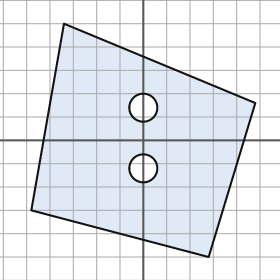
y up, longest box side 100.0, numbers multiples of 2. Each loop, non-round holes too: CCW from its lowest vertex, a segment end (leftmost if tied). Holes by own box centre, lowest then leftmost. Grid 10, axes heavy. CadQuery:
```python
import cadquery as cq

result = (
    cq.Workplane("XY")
    .moveTo(28.0, -50.0)
    .lineTo(48.0, 16.0)
    .lineTo(-34.0, 50.0)
    .lineTo(-48.0, -30.0)
    .close()
    .moveTo(0.0, -12.0)
    .circle(6.0)
    .moveTo(0.0, 14.0)
    .circle(6.0)
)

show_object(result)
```